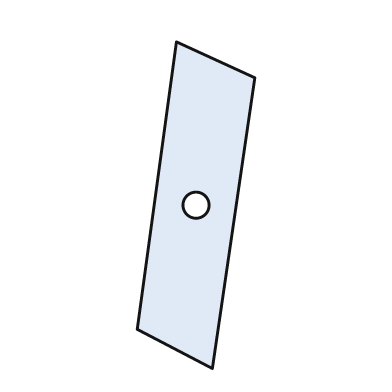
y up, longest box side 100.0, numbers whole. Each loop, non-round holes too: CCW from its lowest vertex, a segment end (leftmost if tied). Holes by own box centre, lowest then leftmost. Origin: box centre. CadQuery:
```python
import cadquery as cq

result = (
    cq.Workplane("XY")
    .moveTo(5.0, -50.0)
    .lineTo(18.0, 39.0)
    .lineTo(-6.0, 50.0)
    .lineTo(-18.0, -38.0)
    .close()
    .moveTo(0.0, 0.0)
    .circle(4.0)
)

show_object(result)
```